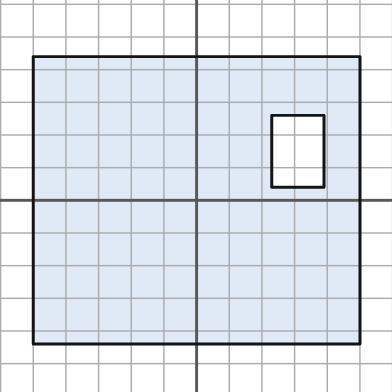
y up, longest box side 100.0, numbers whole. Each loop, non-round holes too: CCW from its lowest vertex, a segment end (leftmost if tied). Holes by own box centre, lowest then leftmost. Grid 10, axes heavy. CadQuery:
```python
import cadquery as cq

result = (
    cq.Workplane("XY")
    .moveTo(-50.0, -44.0)
    .lineTo(50.0, -44.0)
    .lineTo(50.0, 44.0)
    .lineTo(-50.0, 44.0)
    .close()
    .moveTo(23.0, 4.0)
    .lineTo(39.0, 4.0)
    .lineTo(39.0, 26.0)
    .lineTo(23.0, 26.0)
    .close()
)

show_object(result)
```